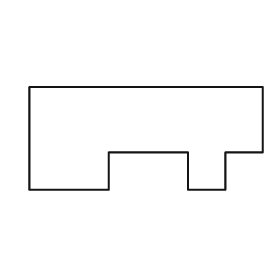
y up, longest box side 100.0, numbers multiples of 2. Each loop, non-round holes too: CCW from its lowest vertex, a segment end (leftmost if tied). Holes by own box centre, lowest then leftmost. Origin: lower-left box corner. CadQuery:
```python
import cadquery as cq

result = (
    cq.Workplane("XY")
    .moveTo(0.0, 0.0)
    .lineTo(34.0, 0.0)
    .lineTo(34.0, 16.0)
    .lineTo(68.0, 16.0)
    .lineTo(68.0, 0.0)
    .lineTo(84.0, 0.0)
    .lineTo(84.0, 16.0)
    .lineTo(100.0, 16.0)
    .lineTo(100.0, 44.0)
    .lineTo(0.0, 44.0)
    .close()
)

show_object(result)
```